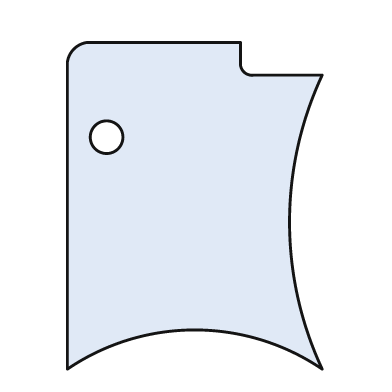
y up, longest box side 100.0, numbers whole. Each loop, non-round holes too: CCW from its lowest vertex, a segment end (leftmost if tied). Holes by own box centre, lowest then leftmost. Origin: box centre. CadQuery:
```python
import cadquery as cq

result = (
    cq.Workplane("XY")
    .moveTo(-39.0, -50.0)
    .threePointArc((0.0, -38.0), (39.0, -50.0))
    .threePointArc((29.0, -5.0), (39.0, 40.0))
    .lineTo(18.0, 40.0)
    .threePointArc((15.0, 41.0), (14.0, 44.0))
    .lineTo(14.0, 50.0)
    .lineTo(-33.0, 50.0)
    .threePointArc((-37.0, 48.0), (-39.0, 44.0))
    .close()
    .moveTo(-27.0, 21.0)
    .circle(5.0)
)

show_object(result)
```